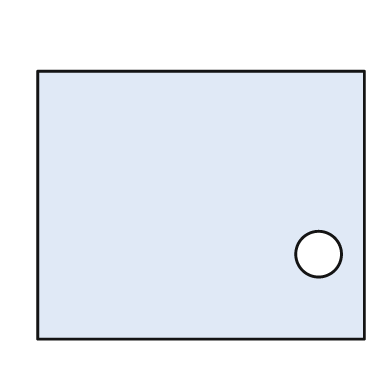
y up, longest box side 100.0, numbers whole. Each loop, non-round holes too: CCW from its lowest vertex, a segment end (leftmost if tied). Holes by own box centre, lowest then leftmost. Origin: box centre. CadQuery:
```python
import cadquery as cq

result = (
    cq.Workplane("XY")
    .moveTo(-50.0, -41.0)
    .lineTo(50.0, -41.0)
    .lineTo(50.0, 41.0)
    .lineTo(-50.0, 41.0)
    .close()
    .moveTo(36.0, -15.0)
    .circle(7.0)
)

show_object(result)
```